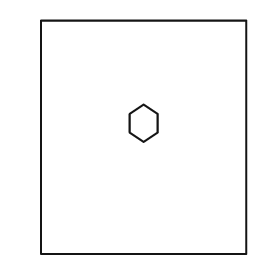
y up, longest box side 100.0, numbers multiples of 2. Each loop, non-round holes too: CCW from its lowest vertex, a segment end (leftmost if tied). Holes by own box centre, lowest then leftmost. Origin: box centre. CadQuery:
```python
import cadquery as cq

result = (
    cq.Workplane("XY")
    .moveTo(-44.0, -50.0)
    .lineTo(44.0, -50.0)
    .lineTo(44.0, 50.0)
    .lineTo(-44.0, 50.0)
    .close()
    .moveTo(0.0, -2.0)
    .lineTo(6.0, 2.0)
    .lineTo(6.0, 10.0)
    .lineTo(0.0, 14.0)
    .lineTo(-6.0, 10.0)
    .lineTo(-6.0, 2.0)
    .close()
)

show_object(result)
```